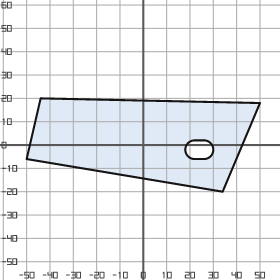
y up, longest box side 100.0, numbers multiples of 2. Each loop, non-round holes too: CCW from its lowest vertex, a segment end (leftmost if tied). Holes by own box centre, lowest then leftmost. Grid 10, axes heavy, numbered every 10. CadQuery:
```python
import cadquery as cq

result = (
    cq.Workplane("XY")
    .moveTo(34.0, -20.0)
    .lineTo(50.0, 18.0)
    .lineTo(-44.0, 20.0)
    .lineTo(-50.0, -6.0)
    .close()
    .moveTo(22.0, -6.0)
    .lineTo(26.0, -6.0)
    .threePointArc((30.0, -2.0), (26.0, 2.0))
    .lineTo(22.0, 2.0)
    .threePointArc((18.0, -2.0), (22.0, -6.0))
    .close()
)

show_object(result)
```